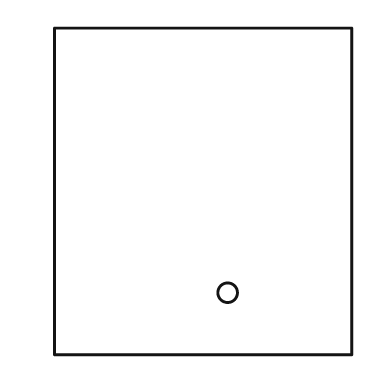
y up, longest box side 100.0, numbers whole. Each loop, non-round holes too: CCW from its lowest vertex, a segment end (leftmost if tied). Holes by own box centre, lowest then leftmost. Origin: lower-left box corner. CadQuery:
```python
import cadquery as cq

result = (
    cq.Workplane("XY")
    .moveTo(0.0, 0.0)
    .lineTo(91.0, 0.0)
    .lineTo(91.0, 100.0)
    .lineTo(0.0, 100.0)
    .close()
    .moveTo(53.0, 19.0)
    .circle(3.0)
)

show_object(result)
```